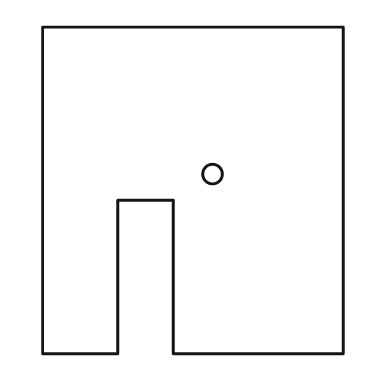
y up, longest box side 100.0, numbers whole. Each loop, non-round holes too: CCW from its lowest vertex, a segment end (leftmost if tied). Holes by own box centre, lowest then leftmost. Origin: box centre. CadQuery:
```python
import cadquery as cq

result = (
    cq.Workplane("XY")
    .moveTo(-46.0, -50.0)
    .lineTo(-23.0, -50.0)
    .lineTo(-23.0, -3.0)
    .lineTo(-6.0, -3.0)
    .lineTo(-6.0, -50.0)
    .lineTo(46.0, -50.0)
    .lineTo(46.0, 50.0)
    .lineTo(-46.0, 50.0)
    .close()
    .moveTo(6.0, 5.0)
    .circle(3.0)
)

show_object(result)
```